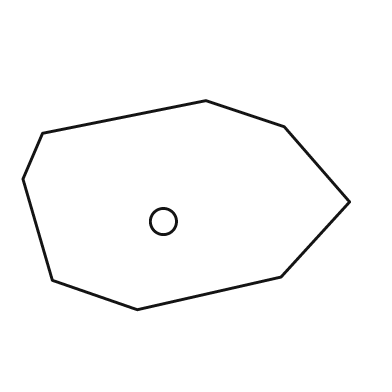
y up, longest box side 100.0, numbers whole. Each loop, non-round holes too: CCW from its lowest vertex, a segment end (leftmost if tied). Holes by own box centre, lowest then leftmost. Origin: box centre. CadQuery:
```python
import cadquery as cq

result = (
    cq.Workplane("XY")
    .moveTo(-15.0, -32.0)
    .lineTo(29.0, -22.0)
    .lineTo(50.0, 1.0)
    .lineTo(30.0, 24.0)
    .lineTo(6.0, 32.0)
    .lineTo(-44.0, 22.0)
    .lineTo(-50.0, 8.0)
    .lineTo(-41.0, -23.0)
    .close()
    .moveTo(-7.0, -5.0)
    .circle(4.0)
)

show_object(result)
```